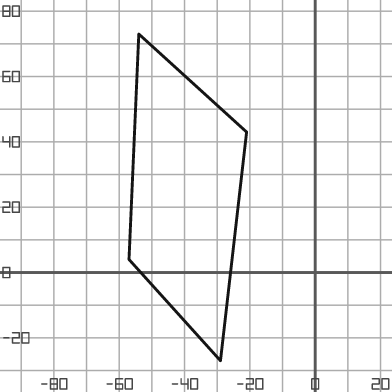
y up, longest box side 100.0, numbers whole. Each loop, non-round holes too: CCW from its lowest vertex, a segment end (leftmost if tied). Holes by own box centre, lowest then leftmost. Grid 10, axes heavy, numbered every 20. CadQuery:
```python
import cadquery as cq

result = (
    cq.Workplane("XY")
    .moveTo(-29.0, -27.0)
    .lineTo(-21.0, 43.0)
    .lineTo(-54.0, 73.0)
    .lineTo(-57.0, 4.0)
    .close()
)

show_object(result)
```